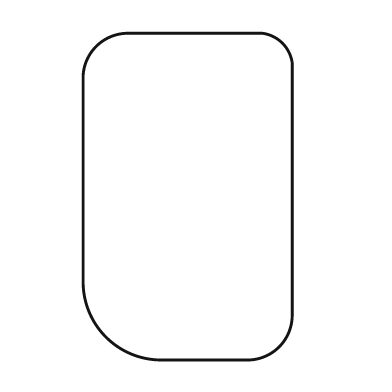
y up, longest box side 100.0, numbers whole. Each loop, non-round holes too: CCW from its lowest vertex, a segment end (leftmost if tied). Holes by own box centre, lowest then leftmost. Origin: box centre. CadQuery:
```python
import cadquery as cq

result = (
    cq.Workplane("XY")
    .moveTo(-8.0, -50.0)
    .lineTo(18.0, -50.0)
    .threePointArc((28.0, -46.0), (32.0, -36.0))
    .lineTo(32.0, 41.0)
    .threePointArc((29.0, 47.0), (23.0, 50.0))
    .lineTo(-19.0, 50.0)
    .threePointArc((-28.0, 46.0), (-32.0, 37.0))
    .lineTo(-32.0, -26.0)
    .threePointArc((-25.0, -43.0), (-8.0, -50.0))
    .close()
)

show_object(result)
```